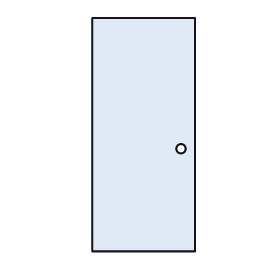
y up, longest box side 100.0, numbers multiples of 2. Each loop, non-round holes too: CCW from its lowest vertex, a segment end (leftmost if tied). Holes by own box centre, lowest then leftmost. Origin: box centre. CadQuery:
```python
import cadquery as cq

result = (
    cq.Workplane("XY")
    .moveTo(-22.0, -50.0)
    .lineTo(22.0, -50.0)
    .lineTo(22.0, 50.0)
    .lineTo(-22.0, 50.0)
    .close()
    .moveTo(16.0, -6.0)
    .circle(2.0)
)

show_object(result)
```